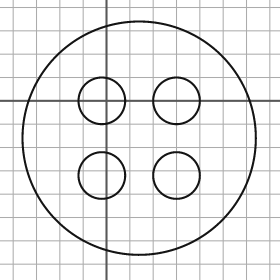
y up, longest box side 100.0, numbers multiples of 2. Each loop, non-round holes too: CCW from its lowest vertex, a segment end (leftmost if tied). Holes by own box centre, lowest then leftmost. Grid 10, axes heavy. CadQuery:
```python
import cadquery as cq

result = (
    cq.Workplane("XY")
    .moveTo(14.0, -16.0)
    .circle(50.0)
    .moveTo(-2.0, -32.0)
    .circle(10.0)
    .moveTo(30.0, -32.0)
    .circle(10.0)
    .moveTo(-2.0, 0.0)
    .circle(10.0)
    .moveTo(30.0, 0.0)
    .circle(10.0)
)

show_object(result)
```